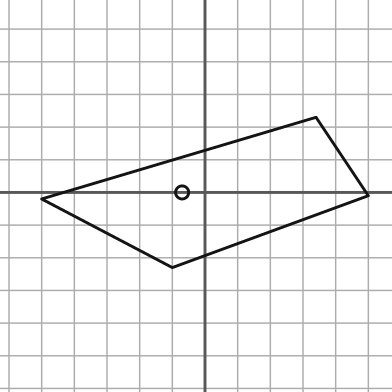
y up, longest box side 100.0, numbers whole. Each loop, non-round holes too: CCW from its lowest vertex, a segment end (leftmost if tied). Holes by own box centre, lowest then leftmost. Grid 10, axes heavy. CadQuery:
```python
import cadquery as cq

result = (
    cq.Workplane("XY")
    .moveTo(-10.0, -23.0)
    .lineTo(50.0, -1.0)
    .lineTo(34.0, 23.0)
    .lineTo(-50.0, -2.0)
    .close()
    .moveTo(-7.0, 0.0)
    .circle(2.0)
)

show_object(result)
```